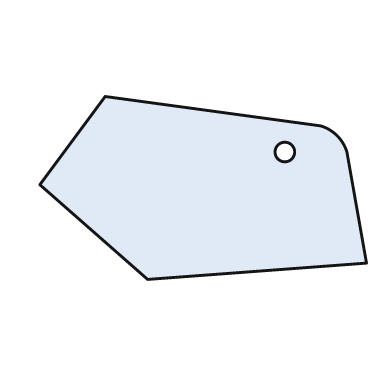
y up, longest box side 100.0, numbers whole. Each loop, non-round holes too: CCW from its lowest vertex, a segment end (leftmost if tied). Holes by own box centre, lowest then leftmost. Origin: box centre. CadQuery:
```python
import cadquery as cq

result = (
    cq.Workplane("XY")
    .moveTo(-17.0, -28.0)
    .lineTo(50.0, -23.0)
    .lineTo(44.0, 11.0)
    .threePointArc((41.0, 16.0), (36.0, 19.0))
    .lineTo(-30.0, 28.0)
    .lineTo(-50.0, 1.0)
    .close()
    .moveTo(25.0, 11.0)
    .circle(3.0)
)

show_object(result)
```